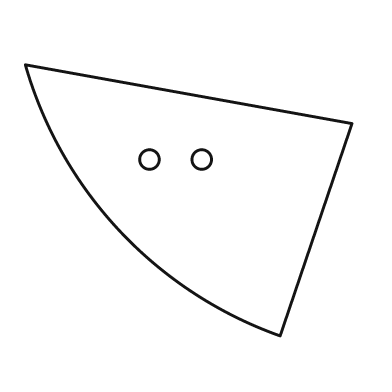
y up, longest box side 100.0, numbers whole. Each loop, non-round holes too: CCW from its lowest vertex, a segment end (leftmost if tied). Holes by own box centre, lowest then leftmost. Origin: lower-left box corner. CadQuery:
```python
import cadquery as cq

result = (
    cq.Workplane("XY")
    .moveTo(78.0, 0.0)
    .lineTo(100.0, 65.0)
    .lineTo(0.0, 83.0)
    .threePointArc((29.0, 32.0), (78.0, 0.0))
    .close()
    .moveTo(38.0, 54.0)
    .circle(3.0)
    .moveTo(54.0, 54.0)
    .circle(3.0)
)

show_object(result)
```